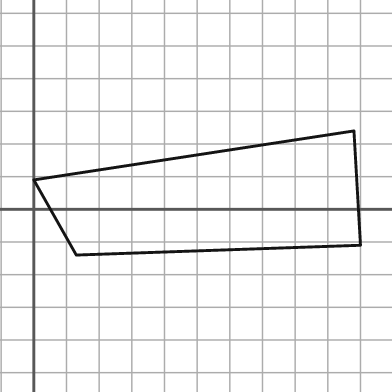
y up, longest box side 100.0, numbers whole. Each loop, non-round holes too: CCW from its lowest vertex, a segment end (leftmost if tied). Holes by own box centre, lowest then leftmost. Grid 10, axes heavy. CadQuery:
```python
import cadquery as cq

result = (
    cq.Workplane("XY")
    .moveTo(13.0, -14.0)
    .lineTo(100.0, -11.0)
    .lineTo(98.0, 24.0)
    .lineTo(0.0, 9.0)
    .close()
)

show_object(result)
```